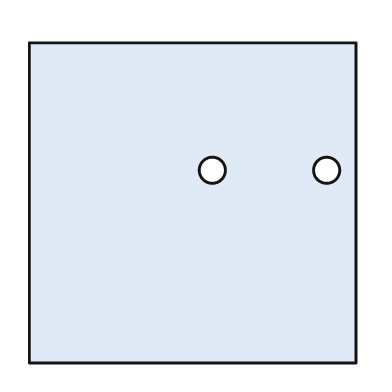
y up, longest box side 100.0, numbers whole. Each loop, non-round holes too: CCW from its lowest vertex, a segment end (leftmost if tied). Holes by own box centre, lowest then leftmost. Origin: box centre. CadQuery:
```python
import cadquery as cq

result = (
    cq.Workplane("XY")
    .moveTo(-50.0, -49.0)
    .lineTo(50.0, -49.0)
    .lineTo(50.0, 49.0)
    .lineTo(-50.0, 49.0)
    .close()
    .moveTo(6.0, 10.0)
    .circle(4.0)
    .moveTo(41.0, 10.0)
    .circle(4.0)
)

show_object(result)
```